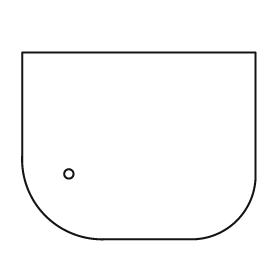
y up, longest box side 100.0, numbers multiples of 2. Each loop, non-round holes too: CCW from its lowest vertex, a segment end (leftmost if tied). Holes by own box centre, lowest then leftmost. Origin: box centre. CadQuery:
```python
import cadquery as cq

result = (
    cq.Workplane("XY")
    .moveTo(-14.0, -40.0)
    .lineTo(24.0, -40.0)
    .threePointArc((42.0, -32.0), (50.0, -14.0))
    .lineTo(50.0, 40.0)
    .lineTo(-50.0, 40.0)
    .lineTo(-50.0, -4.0)
    .threePointArc((-40.0, -30.0), (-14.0, -40.0))
    .close()
    .moveTo(-30.0, -12.0)
    .circle(2.0)
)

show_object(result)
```